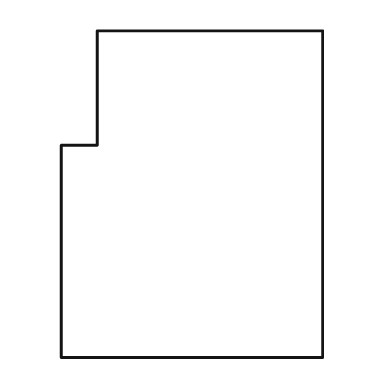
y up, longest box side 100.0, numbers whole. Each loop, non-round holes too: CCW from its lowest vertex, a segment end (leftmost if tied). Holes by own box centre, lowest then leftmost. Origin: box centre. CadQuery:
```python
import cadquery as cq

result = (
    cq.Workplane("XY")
    .moveTo(-40.0, -50.0)
    .lineTo(40.0, -50.0)
    .lineTo(40.0, 50.0)
    .lineTo(-29.0, 50.0)
    .lineTo(-29.0, 15.0)
    .lineTo(-40.0, 15.0)
    .close()
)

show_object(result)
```